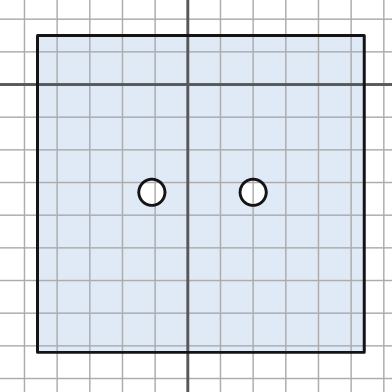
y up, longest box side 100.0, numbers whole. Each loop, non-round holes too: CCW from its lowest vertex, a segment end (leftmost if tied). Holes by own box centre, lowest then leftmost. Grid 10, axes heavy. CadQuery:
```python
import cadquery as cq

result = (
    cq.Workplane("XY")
    .moveTo(-46.0, -82.0)
    .lineTo(54.0, -82.0)
    .lineTo(54.0, 15.0)
    .lineTo(-46.0, 15.0)
    .close()
    .moveTo(-11.0, -33.0)
    .circle(4.0)
    .moveTo(20.0, -33.0)
    .circle(4.0)
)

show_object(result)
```